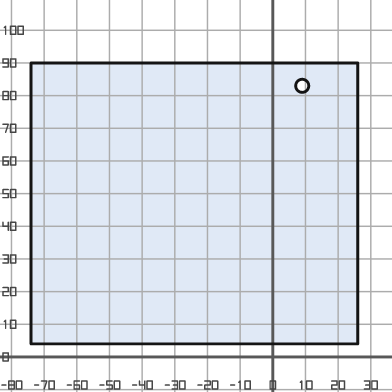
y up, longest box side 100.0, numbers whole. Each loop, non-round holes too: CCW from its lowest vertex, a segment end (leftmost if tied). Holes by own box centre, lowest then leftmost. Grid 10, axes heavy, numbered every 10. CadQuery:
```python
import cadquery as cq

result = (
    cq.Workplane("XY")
    .moveTo(-74.0, 4.0)
    .lineTo(26.0, 4.0)
    .lineTo(26.0, 90.0)
    .lineTo(-74.0, 90.0)
    .close()
    .moveTo(9.0, 83.0)
    .circle(2.0)
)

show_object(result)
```